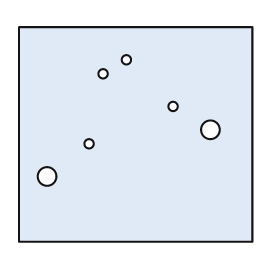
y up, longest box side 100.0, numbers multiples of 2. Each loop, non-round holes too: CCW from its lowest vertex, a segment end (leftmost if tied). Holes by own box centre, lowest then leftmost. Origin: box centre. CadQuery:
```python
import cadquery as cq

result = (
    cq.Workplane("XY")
    .moveTo(-50.0, -46.0)
    .lineTo(50.0, -46.0)
    .lineTo(50.0, 46.0)
    .lineTo(-50.0, 46.0)
    .close()
    .moveTo(-38.0, -18.0)
    .circle(4.0)
    .moveTo(-20.0, -4.0)
    .circle(2.0)
    .moveTo(32.0, 2.0)
    .circle(4.0)
    .moveTo(16.0, 12.0)
    .circle(2.0)
    .moveTo(-14.0, 26.0)
    .circle(2.0)
    .moveTo(-4.0, 32.0)
    .circle(2.0)
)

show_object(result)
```